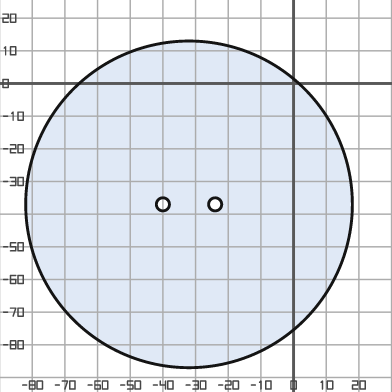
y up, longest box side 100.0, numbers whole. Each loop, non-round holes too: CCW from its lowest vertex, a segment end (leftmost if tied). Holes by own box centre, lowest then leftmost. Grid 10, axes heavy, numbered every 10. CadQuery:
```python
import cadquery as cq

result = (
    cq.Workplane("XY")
    .moveTo(-32.0, -37.0)
    .circle(50.0)
    .moveTo(-40.0, -37.0)
    .circle(2.0)
    .moveTo(-24.0, -37.0)
    .circle(2.0)
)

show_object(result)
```